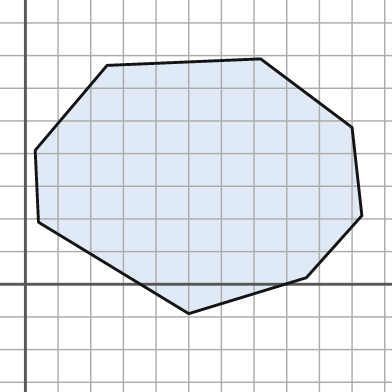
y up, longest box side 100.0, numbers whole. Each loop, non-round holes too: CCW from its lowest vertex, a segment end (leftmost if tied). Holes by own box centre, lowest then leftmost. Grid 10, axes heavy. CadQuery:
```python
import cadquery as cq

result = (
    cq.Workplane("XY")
    .moveTo(50.0, -9.0)
    .lineTo(86.0, 2.0)
    .lineTo(103.0, 21.0)
    .lineTo(100.0, 48.0)
    .lineTo(72.0, 69.0)
    .lineTo(25.0, 67.0)
    .lineTo(3.0, 41.0)
    .lineTo(4.0, 19.0)
    .close()
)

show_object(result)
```